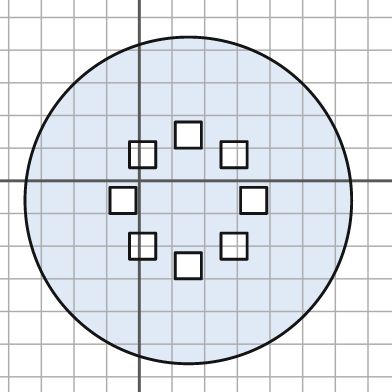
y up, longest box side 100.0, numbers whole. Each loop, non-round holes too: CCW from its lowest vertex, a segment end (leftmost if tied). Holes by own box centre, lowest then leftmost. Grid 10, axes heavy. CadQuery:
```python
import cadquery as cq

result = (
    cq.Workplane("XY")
    .moveTo(15.0, -6.0)
    .circle(50.0)
    .moveTo(11.0, -30.0)
    .lineTo(19.0, -30.0)
    .lineTo(19.0, -22.0)
    .lineTo(11.0, -22.0)
    .close()
    .moveTo(-3.0, -24.0)
    .lineTo(5.0, -24.0)
    .lineTo(5.0, -16.0)
    .lineTo(-3.0, -16.0)
    .close()
    .moveTo(25.0, -24.0)
    .lineTo(33.0, -24.0)
    .lineTo(33.0, -16.0)
    .lineTo(25.0, -16.0)
    .close()
    .moveTo(-9.0, -10.0)
    .lineTo(-1.0, -10.0)
    .lineTo(-1.0, -2.0)
    .lineTo(-9.0, -2.0)
    .close()
    .moveTo(31.0, -10.0)
    .lineTo(39.0, -10.0)
    .lineTo(39.0, -2.0)
    .lineTo(31.0, -2.0)
    .close()
    .moveTo(-3.0, 4.0)
    .lineTo(5.0, 4.0)
    .lineTo(5.0, 12.0)
    .lineTo(-3.0, 12.0)
    .close()
    .moveTo(25.0, 4.0)
    .lineTo(33.0, 4.0)
    .lineTo(33.0, 12.0)
    .lineTo(25.0, 12.0)
    .close()
    .moveTo(11.0, 10.0)
    .lineTo(19.0, 10.0)
    .lineTo(19.0, 18.0)
    .lineTo(11.0, 18.0)
    .close()
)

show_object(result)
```